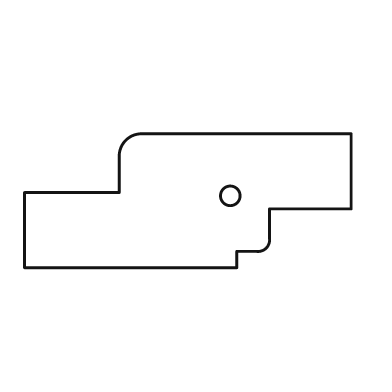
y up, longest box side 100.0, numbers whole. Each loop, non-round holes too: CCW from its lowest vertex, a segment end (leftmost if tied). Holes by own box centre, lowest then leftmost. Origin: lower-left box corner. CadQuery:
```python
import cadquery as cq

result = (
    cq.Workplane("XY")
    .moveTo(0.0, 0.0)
    .lineTo(65.0, 0.0)
    .lineTo(65.0, 5.0)
    .lineTo(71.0, 5.0)
    .threePointArc((74.0, 6.0), (75.0, 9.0))
    .lineTo(75.0, 18.0)
    .lineTo(100.0, 18.0)
    .lineTo(100.0, 41.0)
    .lineTo(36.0, 41.0)
    .threePointArc((31.0, 39.0), (29.0, 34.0))
    .lineTo(29.0, 23.0)
    .lineTo(0.0, 23.0)
    .close()
    .moveTo(63.0, 22.0)
    .circle(3.0)
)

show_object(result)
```